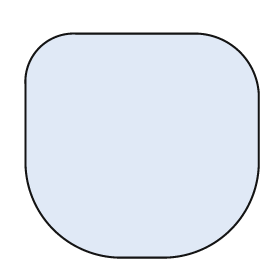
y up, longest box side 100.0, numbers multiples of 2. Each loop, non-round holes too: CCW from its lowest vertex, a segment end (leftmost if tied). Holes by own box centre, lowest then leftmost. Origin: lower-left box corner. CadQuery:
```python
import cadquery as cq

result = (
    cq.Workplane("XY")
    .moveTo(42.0, 0.0)
    .lineTo(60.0, 0.0)
    .threePointArc((88.0, 12.0), (100.0, 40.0))
    .lineTo(100.0, 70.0)
    .threePointArc((92.0, 88.0), (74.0, 96.0))
    .lineTo(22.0, 96.0)
    .threePointArc((6.0, 90.0), (0.0, 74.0))
    .lineTo(0.0, 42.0)
    .threePointArc((12.0, 12.0), (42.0, 0.0))
    .close()
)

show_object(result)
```